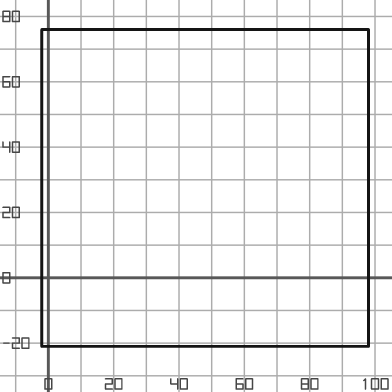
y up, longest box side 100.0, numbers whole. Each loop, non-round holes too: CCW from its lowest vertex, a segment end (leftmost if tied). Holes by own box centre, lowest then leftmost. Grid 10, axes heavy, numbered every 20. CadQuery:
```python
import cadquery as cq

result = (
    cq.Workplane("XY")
    .moveTo(-2.0, -21.0)
    .lineTo(98.0, -21.0)
    .lineTo(98.0, 76.0)
    .lineTo(-2.0, 76.0)
    .close()
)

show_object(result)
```